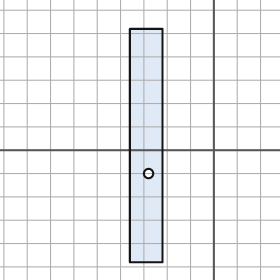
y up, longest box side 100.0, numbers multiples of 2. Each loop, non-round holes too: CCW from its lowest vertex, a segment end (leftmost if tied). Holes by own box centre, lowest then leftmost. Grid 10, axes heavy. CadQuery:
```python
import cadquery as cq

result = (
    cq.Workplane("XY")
    .moveTo(-36.0, -48.0)
    .lineTo(-22.0, -48.0)
    .lineTo(-22.0, 52.0)
    .lineTo(-36.0, 52.0)
    .close()
    .moveTo(-28.0, -10.0)
    .circle(2.0)
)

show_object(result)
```